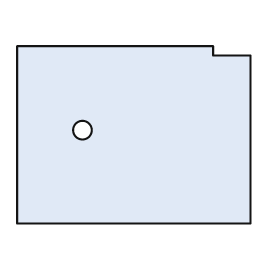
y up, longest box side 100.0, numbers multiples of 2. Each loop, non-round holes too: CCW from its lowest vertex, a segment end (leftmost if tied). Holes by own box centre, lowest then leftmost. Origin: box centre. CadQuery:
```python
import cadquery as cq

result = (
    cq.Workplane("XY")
    .moveTo(-50.0, -38.0)
    .lineTo(50.0, -38.0)
    .lineTo(50.0, 34.0)
    .lineTo(34.0, 34.0)
    .lineTo(34.0, 38.0)
    .lineTo(-50.0, 38.0)
    .close()
    .moveTo(-22.0, 2.0)
    .circle(4.0)
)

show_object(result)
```